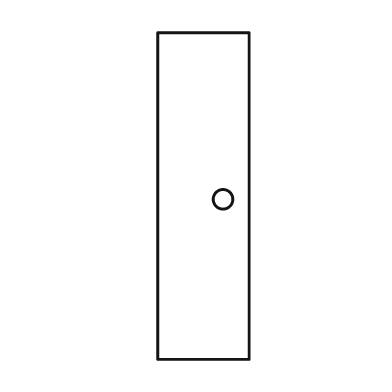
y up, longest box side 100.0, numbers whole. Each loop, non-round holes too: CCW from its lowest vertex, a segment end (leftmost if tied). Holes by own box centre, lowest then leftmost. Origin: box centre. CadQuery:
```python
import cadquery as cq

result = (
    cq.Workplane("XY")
    .moveTo(-14.0, -50.0)
    .lineTo(14.0, -50.0)
    .lineTo(14.0, 50.0)
    .lineTo(-14.0, 50.0)
    .close()
    .moveTo(6.0, -1.0)
    .circle(3.0)
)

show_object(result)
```